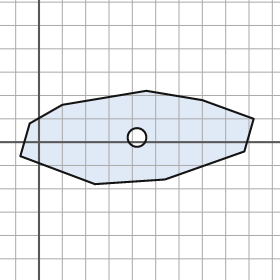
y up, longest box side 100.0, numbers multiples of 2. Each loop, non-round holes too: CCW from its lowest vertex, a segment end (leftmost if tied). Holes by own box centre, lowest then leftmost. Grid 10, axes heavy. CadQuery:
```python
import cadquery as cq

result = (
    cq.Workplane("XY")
    .moveTo(24.0, -18.0)
    .lineTo(54.0, -16.0)
    .lineTo(88.0, -4.0)
    .lineTo(92.0, 10.0)
    .lineTo(70.0, 18.0)
    .lineTo(46.0, 22.0)
    .lineTo(10.0, 16.0)
    .lineTo(-4.0, 8.0)
    .lineTo(-8.0, -6.0)
    .close()
    .moveTo(42.0, 2.0)
    .circle(4.0)
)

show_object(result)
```